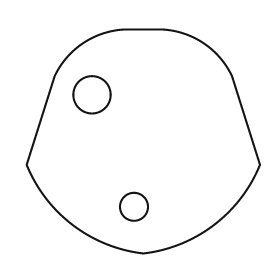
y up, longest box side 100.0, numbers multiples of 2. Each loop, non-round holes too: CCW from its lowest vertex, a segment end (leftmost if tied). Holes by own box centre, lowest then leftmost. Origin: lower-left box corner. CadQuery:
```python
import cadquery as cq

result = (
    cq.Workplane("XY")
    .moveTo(50.0, 0.0)
    .threePointArc((80.0, 12.0), (100.0, 38.0))
    .lineTo(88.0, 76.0)
    .threePointArc((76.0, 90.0), (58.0, 96.0))
    .lineTo(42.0, 96.0)
    .threePointArc((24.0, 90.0), (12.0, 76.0))
    .lineTo(0.0, 38.0)
    .threePointArc((20.0, 12.0), (50.0, 0.0))
    .close()
    .moveTo(46.0, 20.0)
    .circle(6.0)
    .moveTo(28.0, 68.0)
    .circle(8.0)
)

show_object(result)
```